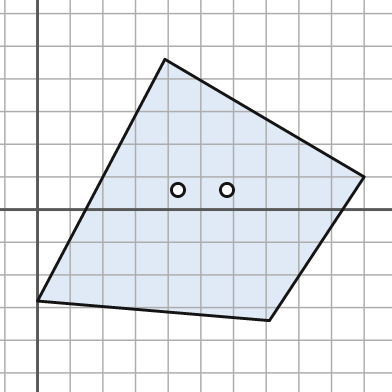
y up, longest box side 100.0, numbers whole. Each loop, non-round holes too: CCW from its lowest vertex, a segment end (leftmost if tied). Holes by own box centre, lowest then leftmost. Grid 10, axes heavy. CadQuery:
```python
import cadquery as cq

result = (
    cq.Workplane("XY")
    .moveTo(71.0, -34.0)
    .lineTo(100.0, 10.0)
    .lineTo(39.0, 46.0)
    .lineTo(0.0, -28.0)
    .close()
    .moveTo(43.0, 6.0)
    .circle(2.0)
    .moveTo(58.0, 6.0)
    .circle(2.0)
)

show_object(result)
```